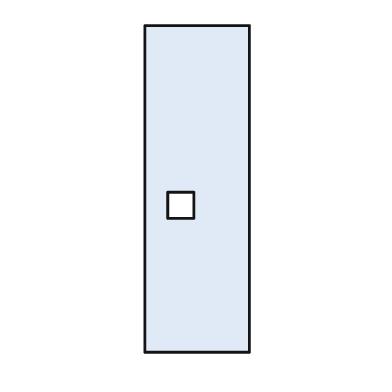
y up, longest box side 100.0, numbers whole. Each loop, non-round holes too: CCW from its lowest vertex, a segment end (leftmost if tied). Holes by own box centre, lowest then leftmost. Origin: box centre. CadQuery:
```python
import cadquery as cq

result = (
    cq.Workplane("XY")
    .moveTo(-16.0, -50.0)
    .lineTo(16.0, -50.0)
    .lineTo(16.0, 50.0)
    .lineTo(-16.0, 50.0)
    .close()
    .moveTo(-9.0, -9.0)
    .lineTo(-1.0, -9.0)
    .lineTo(-1.0, -1.0)
    .lineTo(-9.0, -1.0)
    .close()
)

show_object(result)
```